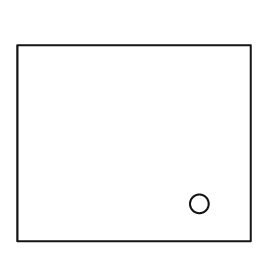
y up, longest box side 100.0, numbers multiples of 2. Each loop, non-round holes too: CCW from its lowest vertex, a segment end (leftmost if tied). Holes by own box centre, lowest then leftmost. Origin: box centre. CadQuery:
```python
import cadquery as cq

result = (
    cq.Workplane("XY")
    .moveTo(-50.0, -42.0)
    .lineTo(50.0, -42.0)
    .lineTo(50.0, 42.0)
    .lineTo(-50.0, 42.0)
    .close()
    .moveTo(28.0, -26.0)
    .circle(4.0)
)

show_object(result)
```